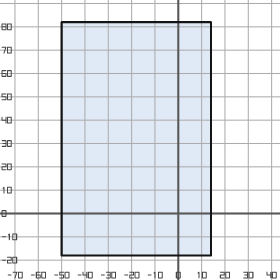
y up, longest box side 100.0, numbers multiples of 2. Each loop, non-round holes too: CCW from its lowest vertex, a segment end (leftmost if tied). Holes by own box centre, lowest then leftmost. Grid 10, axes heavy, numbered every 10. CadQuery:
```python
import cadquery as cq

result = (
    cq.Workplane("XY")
    .moveTo(-50.0, -18.0)
    .lineTo(14.0, -18.0)
    .lineTo(14.0, 82.0)
    .lineTo(-50.0, 82.0)
    .close()
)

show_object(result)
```